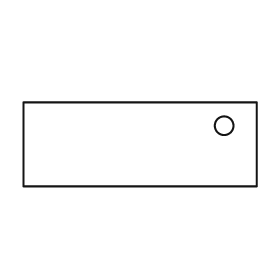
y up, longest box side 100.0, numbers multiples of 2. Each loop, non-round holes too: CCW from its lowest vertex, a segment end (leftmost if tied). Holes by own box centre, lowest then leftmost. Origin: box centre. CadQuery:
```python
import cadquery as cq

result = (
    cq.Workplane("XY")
    .moveTo(-50.0, -18.0)
    .lineTo(50.0, -18.0)
    .lineTo(50.0, 18.0)
    .lineTo(-50.0, 18.0)
    .close()
    .moveTo(36.0, 8.0)
    .circle(4.0)
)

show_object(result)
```